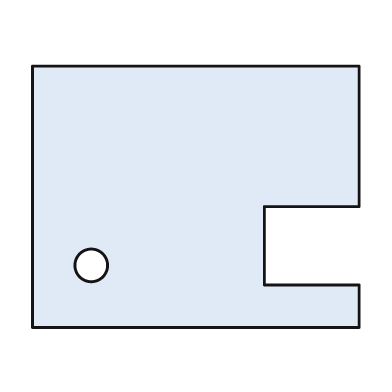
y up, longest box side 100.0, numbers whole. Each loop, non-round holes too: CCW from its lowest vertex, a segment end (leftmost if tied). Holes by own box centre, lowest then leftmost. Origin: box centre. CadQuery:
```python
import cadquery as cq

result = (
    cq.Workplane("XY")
    .moveTo(-50.0, -40.0)
    .lineTo(50.0, -40.0)
    .lineTo(50.0, -27.0)
    .lineTo(21.0, -27.0)
    .lineTo(21.0, -3.0)
    .lineTo(50.0, -3.0)
    .lineTo(50.0, 40.0)
    .lineTo(-50.0, 40.0)
    .close()
    .moveTo(-32.0, -21.0)
    .circle(5.0)
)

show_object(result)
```